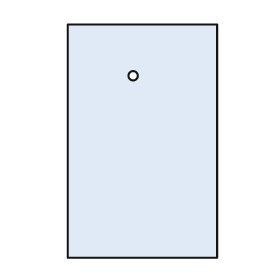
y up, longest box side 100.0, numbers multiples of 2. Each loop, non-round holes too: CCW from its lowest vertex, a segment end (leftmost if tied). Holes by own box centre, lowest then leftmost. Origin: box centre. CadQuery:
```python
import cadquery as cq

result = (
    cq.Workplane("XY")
    .moveTo(-32.0, -50.0)
    .lineTo(32.0, -50.0)
    .lineTo(32.0, 50.0)
    .lineTo(-32.0, 50.0)
    .close()
    .moveTo(-4.0, 28.0)
    .circle(2.0)
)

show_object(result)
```